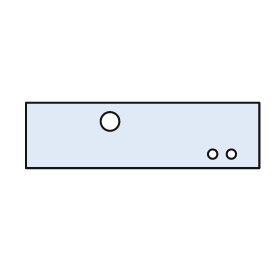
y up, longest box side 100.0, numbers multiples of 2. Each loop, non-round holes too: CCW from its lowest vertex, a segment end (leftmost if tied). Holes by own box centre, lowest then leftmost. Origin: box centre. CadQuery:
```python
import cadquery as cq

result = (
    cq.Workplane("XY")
    .moveTo(-50.0, -14.0)
    .lineTo(50.0, -14.0)
    .lineTo(50.0, 14.0)
    .lineTo(-50.0, 14.0)
    .close()
    .moveTo(30.0, -8.0)
    .circle(2.0)
    .moveTo(38.0, -8.0)
    .circle(2.0)
    .moveTo(-14.0, 6.0)
    .circle(4.0)
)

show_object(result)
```